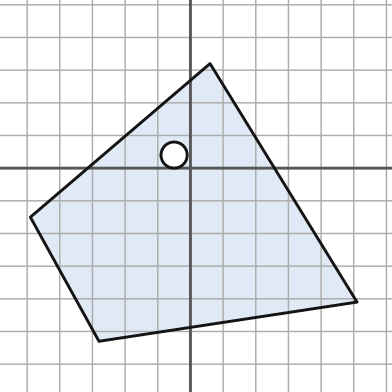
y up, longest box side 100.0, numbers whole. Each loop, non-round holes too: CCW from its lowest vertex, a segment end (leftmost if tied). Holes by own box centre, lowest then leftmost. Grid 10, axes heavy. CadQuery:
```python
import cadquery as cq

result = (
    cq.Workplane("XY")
    .moveTo(-28.0, -53.0)
    .lineTo(51.0, -41.0)
    .lineTo(6.0, 32.0)
    .lineTo(-49.0, -15.0)
    .close()
    .moveTo(-5.0, 4.0)
    .circle(4.0)
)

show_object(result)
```